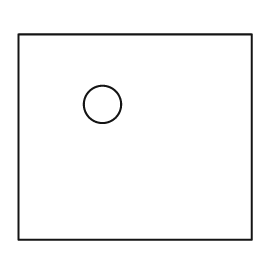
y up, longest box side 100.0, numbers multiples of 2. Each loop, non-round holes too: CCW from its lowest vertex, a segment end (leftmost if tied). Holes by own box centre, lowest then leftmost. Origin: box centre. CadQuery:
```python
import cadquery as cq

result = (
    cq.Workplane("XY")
    .moveTo(-50.0, -44.0)
    .lineTo(50.0, -44.0)
    .lineTo(50.0, 44.0)
    .lineTo(-50.0, 44.0)
    .close()
    .moveTo(-14.0, 14.0)
    .circle(8.0)
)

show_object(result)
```